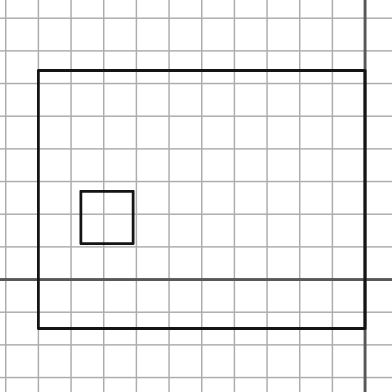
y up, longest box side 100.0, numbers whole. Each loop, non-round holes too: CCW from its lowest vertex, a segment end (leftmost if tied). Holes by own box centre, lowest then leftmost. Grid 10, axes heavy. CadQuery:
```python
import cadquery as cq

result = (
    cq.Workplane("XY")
    .moveTo(-100.0, -15.0)
    .lineTo(0.0, -15.0)
    .lineTo(0.0, 64.0)
    .lineTo(-100.0, 64.0)
    .close()
    .moveTo(-87.0, 11.0)
    .lineTo(-71.0, 11.0)
    .lineTo(-71.0, 27.0)
    .lineTo(-87.0, 27.0)
    .close()
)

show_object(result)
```